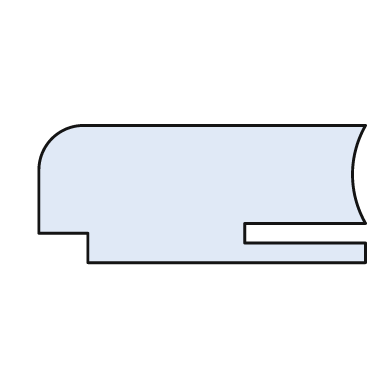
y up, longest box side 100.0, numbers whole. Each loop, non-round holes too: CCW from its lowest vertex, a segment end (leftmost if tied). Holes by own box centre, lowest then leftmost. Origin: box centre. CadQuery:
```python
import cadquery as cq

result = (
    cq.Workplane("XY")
    .moveTo(-35.0, -21.0)
    .lineTo(50.0, -21.0)
    .lineTo(50.0, -15.0)
    .lineTo(13.0, -15.0)
    .lineTo(13.0, -9.0)
    .lineTo(50.0, -9.0)
    .threePointArc((46.0, 6.0), (50.0, 21.0))
    .lineTo(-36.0, 21.0)
    .threePointArc((-46.0, 17.0), (-50.0, 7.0))
    .lineTo(-50.0, -12.0)
    .lineTo(-35.0, -12.0)
    .close()
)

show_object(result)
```